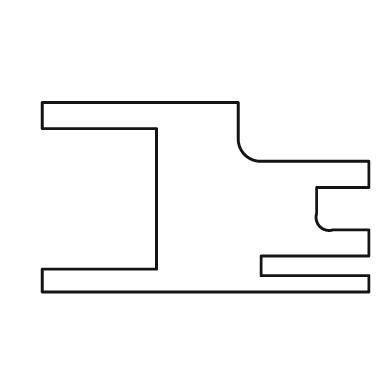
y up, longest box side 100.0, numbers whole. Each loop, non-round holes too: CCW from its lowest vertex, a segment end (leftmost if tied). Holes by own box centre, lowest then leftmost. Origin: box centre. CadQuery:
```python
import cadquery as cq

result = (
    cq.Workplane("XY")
    .moveTo(-50.0, -29.0)
    .lineTo(50.0, -29.0)
    .lineTo(50.0, -24.0)
    .lineTo(17.0, -24.0)
    .lineTo(17.0, -18.0)
    .lineTo(50.0, -18.0)
    .lineTo(50.0, -10.0)
    .lineTo(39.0, -10.0)
    .threePointArc((35.0, -9.0), (34.0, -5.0))
    .lineTo(34.0, 3.0)
    .lineTo(50.0, 3.0)
    .lineTo(50.0, 11.0)
    .lineTo(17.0, 11.0)
    .threePointArc((12.0, 13.0), (10.0, 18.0))
    .lineTo(10.0, 29.0)
    .lineTo(-50.0, 29.0)
    .lineTo(-50.0, 21.0)
    .lineTo(-15.0, 21.0)
    .lineTo(-15.0, -22.0)
    .lineTo(-50.0, -22.0)
    .close()
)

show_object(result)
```